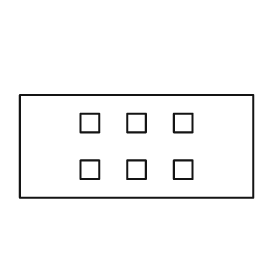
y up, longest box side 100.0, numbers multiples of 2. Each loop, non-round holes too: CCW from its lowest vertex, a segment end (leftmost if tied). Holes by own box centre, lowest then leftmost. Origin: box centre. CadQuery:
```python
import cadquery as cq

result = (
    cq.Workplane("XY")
    .moveTo(-50.0, -22.0)
    .lineTo(50.0, -22.0)
    .lineTo(50.0, 22.0)
    .lineTo(-50.0, 22.0)
    .close()
    .moveTo(-24.0, -14.0)
    .lineTo(-16.0, -14.0)
    .lineTo(-16.0, -6.0)
    .lineTo(-24.0, -6.0)
    .close()
    .moveTo(-4.0, -14.0)
    .lineTo(4.0, -14.0)
    .lineTo(4.0, -6.0)
    .lineTo(-4.0, -6.0)
    .close()
    .moveTo(16.0, -14.0)
    .lineTo(24.0, -14.0)
    .lineTo(24.0, -6.0)
    .lineTo(16.0, -6.0)
    .close()
    .moveTo(-24.0, 6.0)
    .lineTo(-16.0, 6.0)
    .lineTo(-16.0, 14.0)
    .lineTo(-24.0, 14.0)
    .close()
    .moveTo(-4.0, 6.0)
    .lineTo(4.0, 6.0)
    .lineTo(4.0, 14.0)
    .lineTo(-4.0, 14.0)
    .close()
    .moveTo(16.0, 6.0)
    .lineTo(24.0, 6.0)
    .lineTo(24.0, 14.0)
    .lineTo(16.0, 14.0)
    .close()
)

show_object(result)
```